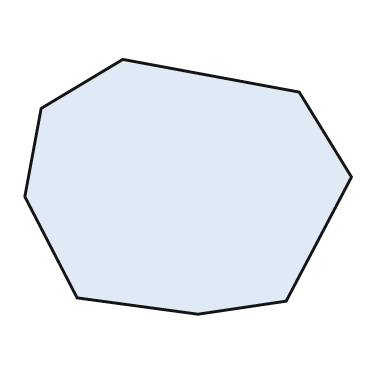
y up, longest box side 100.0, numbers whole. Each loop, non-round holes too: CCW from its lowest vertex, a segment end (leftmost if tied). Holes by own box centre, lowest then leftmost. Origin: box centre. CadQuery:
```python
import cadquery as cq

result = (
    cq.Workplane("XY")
    .moveTo(3.0, -39.0)
    .lineTo(30.0, -35.0)
    .lineTo(50.0, 3.0)
    .lineTo(34.0, 29.0)
    .lineTo(-20.0, 39.0)
    .lineTo(-45.0, 24.0)
    .lineTo(-50.0, -3.0)
    .lineTo(-34.0, -34.0)
    .close()
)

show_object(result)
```